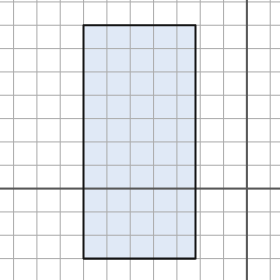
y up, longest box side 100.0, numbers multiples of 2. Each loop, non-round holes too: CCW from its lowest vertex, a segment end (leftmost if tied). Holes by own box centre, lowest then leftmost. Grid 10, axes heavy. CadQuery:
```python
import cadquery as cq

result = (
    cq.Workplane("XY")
    .moveTo(-70.0, -30.0)
    .lineTo(-22.0, -30.0)
    .lineTo(-22.0, 70.0)
    .lineTo(-70.0, 70.0)
    .close()
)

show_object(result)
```